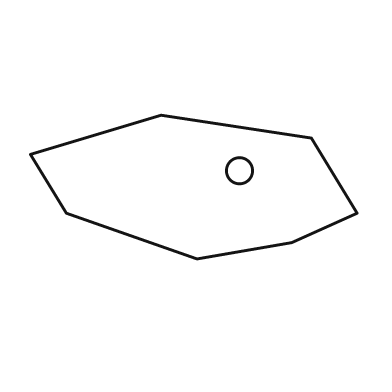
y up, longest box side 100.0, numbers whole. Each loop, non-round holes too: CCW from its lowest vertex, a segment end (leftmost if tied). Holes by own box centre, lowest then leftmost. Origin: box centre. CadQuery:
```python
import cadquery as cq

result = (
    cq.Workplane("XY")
    .moveTo(1.0, -22.0)
    .lineTo(30.0, -17.0)
    .lineTo(50.0, -8.0)
    .lineTo(36.0, 15.0)
    .lineTo(-10.0, 22.0)
    .lineTo(-50.0, 10.0)
    .lineTo(-39.0, -8.0)
    .close()
    .moveTo(14.0, 5.0)
    .circle(4.0)
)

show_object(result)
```